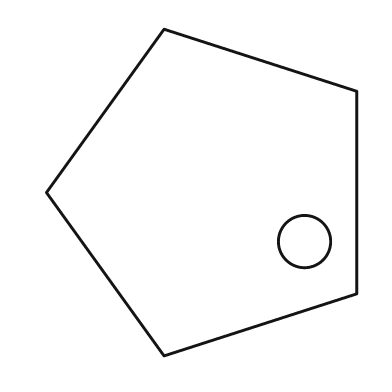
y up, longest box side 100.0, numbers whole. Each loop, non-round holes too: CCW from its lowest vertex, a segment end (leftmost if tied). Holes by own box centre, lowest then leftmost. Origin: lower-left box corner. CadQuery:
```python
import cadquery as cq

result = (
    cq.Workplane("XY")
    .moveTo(36.0, 0.0)
    .lineTo(95.0, 19.0)
    .lineTo(95.0, 81.0)
    .lineTo(36.0, 100.0)
    .lineTo(0.0, 50.0)
    .close()
    .moveTo(79.0, 35.0)
    .circle(8.0)
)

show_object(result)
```